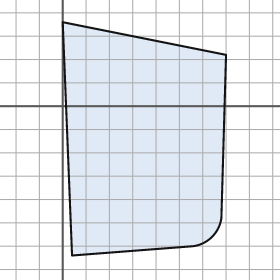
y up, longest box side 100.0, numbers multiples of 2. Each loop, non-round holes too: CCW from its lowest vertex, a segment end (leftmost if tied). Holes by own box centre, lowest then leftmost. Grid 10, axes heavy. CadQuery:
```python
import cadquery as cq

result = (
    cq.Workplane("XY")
    .moveTo(4.0, -64.0)
    .lineTo(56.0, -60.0)
    .threePointArc((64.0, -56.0), (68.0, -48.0))
    .lineTo(70.0, 22.0)
    .lineTo(0.0, 36.0)
    .close()
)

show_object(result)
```